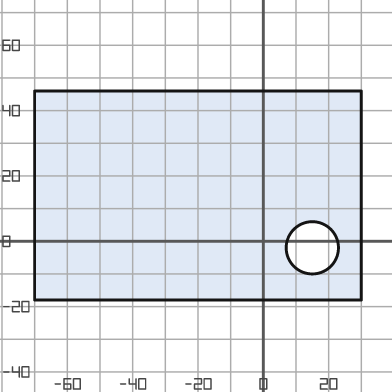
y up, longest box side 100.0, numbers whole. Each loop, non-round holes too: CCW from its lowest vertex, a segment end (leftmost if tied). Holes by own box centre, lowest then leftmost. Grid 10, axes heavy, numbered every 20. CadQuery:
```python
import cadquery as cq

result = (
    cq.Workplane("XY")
    .moveTo(-70.0, -18.0)
    .lineTo(30.0, -18.0)
    .lineTo(30.0, 46.0)
    .lineTo(-70.0, 46.0)
    .close()
    .moveTo(15.0, -2.0)
    .circle(8.0)
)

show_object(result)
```